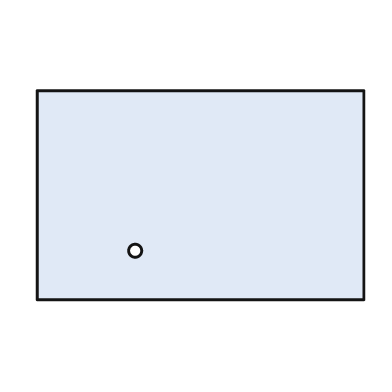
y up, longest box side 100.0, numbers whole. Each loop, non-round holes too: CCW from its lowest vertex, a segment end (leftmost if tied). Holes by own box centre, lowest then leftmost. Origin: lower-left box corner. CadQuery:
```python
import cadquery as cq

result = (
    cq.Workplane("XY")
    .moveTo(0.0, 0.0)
    .lineTo(100.0, 0.0)
    .lineTo(100.0, 64.0)
    .lineTo(0.0, 64.0)
    .close()
    .moveTo(30.0, 15.0)
    .circle(2.0)
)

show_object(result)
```